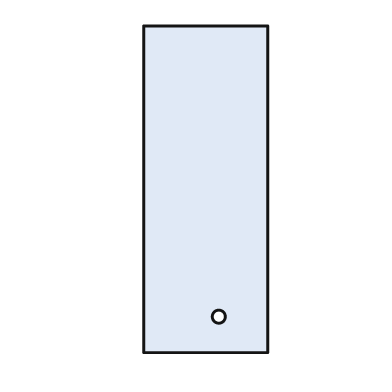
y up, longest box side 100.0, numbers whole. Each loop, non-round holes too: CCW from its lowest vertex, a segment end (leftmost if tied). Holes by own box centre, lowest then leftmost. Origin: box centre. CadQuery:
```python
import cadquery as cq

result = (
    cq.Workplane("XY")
    .moveTo(-19.0, -50.0)
    .lineTo(19.0, -50.0)
    .lineTo(19.0, 50.0)
    .lineTo(-19.0, 50.0)
    .close()
    .moveTo(4.0, -39.0)
    .circle(2.0)
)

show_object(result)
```